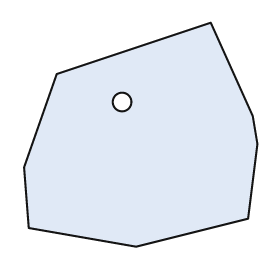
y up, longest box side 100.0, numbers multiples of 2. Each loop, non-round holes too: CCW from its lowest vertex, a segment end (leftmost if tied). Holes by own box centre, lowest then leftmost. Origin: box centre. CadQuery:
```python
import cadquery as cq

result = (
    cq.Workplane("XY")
    .moveTo(-2.0, -48.0)
    .lineTo(46.0, -36.0)
    .lineTo(50.0, -4.0)
    .lineTo(48.0, 8.0)
    .lineTo(30.0, 48.0)
    .lineTo(-36.0, 26.0)
    .lineTo(-50.0, -14.0)
    .lineTo(-48.0, -40.0)
    .close()
    .moveTo(-8.0, 14.0)
    .circle(4.0)
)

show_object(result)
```